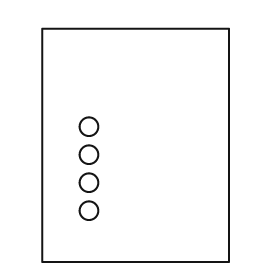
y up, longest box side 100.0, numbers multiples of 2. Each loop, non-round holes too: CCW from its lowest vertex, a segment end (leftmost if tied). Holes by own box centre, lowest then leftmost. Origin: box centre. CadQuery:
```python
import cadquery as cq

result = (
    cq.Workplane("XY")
    .moveTo(-40.0, -50.0)
    .lineTo(40.0, -50.0)
    .lineTo(40.0, 50.0)
    .lineTo(-40.0, 50.0)
    .close()
    .moveTo(-20.0, -28.0)
    .circle(4.0)
    .moveTo(-20.0, -16.0)
    .circle(4.0)
    .moveTo(-20.0, -4.0)
    .circle(4.0)
    .moveTo(-20.0, 8.0)
    .circle(4.0)
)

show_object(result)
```